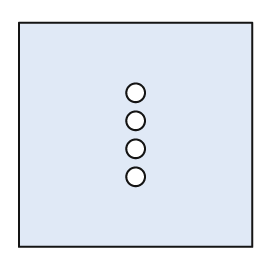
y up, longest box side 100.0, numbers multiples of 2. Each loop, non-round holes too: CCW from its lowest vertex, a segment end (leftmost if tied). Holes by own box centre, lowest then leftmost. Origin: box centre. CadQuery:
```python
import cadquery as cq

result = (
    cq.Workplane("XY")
    .moveTo(-50.0, -48.0)
    .lineTo(50.0, -48.0)
    .lineTo(50.0, 48.0)
    .lineTo(-50.0, 48.0)
    .close()
    .moveTo(0.0, -18.0)
    .circle(4.0)
    .moveTo(0.0, -6.0)
    .circle(4.0)
    .moveTo(0.0, 6.0)
    .circle(4.0)
    .moveTo(0.0, 18.0)
    .circle(4.0)
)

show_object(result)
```